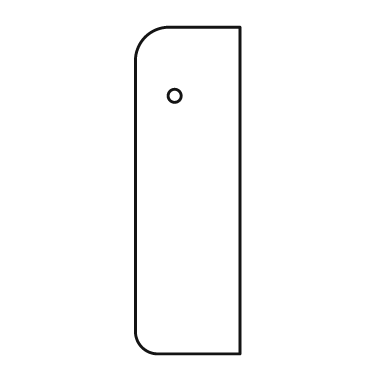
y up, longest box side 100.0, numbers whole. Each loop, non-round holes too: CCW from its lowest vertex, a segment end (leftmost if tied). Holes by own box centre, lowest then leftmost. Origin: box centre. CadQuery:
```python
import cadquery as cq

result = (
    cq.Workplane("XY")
    .moveTo(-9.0, -50.0)
    .lineTo(16.0, -50.0)
    .lineTo(16.0, 50.0)
    .lineTo(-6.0, 50.0)
    .threePointArc((-13.0, 47.0), (-16.0, 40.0))
    .lineTo(-16.0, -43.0)
    .threePointArc((-14.0, -48.0), (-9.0, -50.0))
    .close()
    .moveTo(-4.0, 29.0)
    .circle(2.0)
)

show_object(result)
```